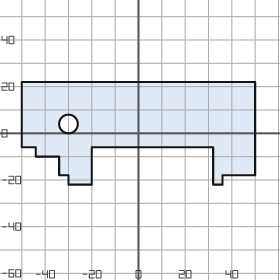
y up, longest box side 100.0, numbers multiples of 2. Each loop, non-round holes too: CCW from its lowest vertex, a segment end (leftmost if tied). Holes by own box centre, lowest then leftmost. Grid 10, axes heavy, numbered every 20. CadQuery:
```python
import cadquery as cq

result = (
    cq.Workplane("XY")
    .moveTo(-30.0, -22.0)
    .lineTo(-20.0, -22.0)
    .lineTo(-20.0, -6.0)
    .lineTo(32.0, -6.0)
    .lineTo(32.0, -22.0)
    .lineTo(36.0, -22.0)
    .lineTo(36.0, -18.0)
    .lineTo(50.0, -18.0)
    .lineTo(50.0, 22.0)
    .lineTo(-50.0, 22.0)
    .lineTo(-50.0, -6.0)
    .lineTo(-44.0, -6.0)
    .lineTo(-44.0, -10.0)
    .lineTo(-34.0, -10.0)
    .lineTo(-34.0, -18.0)
    .lineTo(-30.0, -18.0)
    .close()
    .moveTo(-30.0, 4.0)
    .circle(4.0)
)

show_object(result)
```